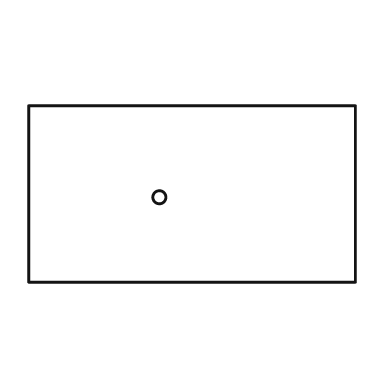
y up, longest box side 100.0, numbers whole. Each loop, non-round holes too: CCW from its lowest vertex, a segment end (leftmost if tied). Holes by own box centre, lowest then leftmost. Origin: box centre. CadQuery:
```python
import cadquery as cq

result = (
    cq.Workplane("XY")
    .moveTo(-50.0, -27.0)
    .lineTo(50.0, -27.0)
    .lineTo(50.0, 27.0)
    .lineTo(-50.0, 27.0)
    .close()
    .moveTo(-10.0, -1.0)
    .circle(2.0)
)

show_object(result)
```